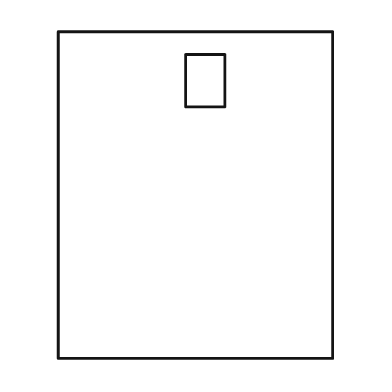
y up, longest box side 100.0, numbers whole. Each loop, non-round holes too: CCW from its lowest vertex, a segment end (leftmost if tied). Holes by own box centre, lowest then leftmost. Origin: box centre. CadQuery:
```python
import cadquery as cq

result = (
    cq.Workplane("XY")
    .moveTo(-42.0, -50.0)
    .lineTo(42.0, -50.0)
    .lineTo(42.0, 50.0)
    .lineTo(-42.0, 50.0)
    .close()
    .moveTo(-3.0, 27.0)
    .lineTo(9.0, 27.0)
    .lineTo(9.0, 43.0)
    .lineTo(-3.0, 43.0)
    .close()
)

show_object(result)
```